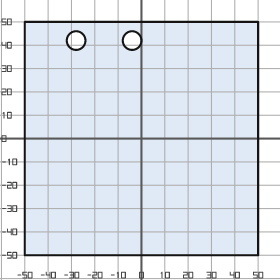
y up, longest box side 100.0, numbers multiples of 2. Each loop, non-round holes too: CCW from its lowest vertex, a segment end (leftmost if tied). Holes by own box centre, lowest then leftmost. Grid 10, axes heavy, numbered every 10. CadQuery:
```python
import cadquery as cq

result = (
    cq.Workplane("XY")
    .moveTo(-50.0, -50.0)
    .lineTo(50.0, -50.0)
    .lineTo(50.0, 50.0)
    .lineTo(-50.0, 50.0)
    .close()
    .moveTo(-28.0, 42.0)
    .circle(4.0)
    .moveTo(-4.0, 42.0)
    .circle(4.0)
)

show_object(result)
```